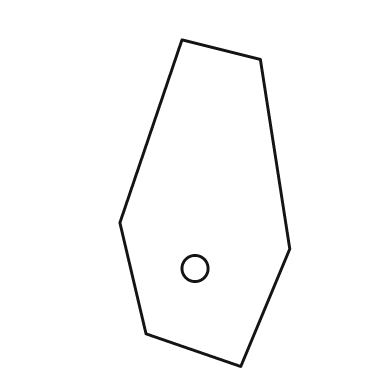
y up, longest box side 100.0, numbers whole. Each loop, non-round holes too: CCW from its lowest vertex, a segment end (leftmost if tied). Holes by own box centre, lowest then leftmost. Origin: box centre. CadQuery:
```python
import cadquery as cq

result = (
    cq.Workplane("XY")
    .moveTo(11.0, -50.0)
    .lineTo(26.0, -14.0)
    .lineTo(17.0, 44.0)
    .lineTo(-7.0, 50.0)
    .lineTo(-26.0, -6.0)
    .lineTo(-18.0, -40.0)
    .close()
    .moveTo(-3.0, -20.0)
    .circle(4.0)
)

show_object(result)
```